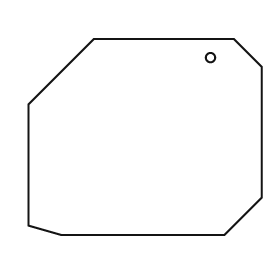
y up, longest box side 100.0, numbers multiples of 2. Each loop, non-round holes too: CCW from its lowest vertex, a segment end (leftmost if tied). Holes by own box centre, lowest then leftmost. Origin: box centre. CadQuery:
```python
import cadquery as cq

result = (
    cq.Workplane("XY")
    .moveTo(-36.0, -42.0)
    .lineTo(34.0, -42.0)
    .lineTo(50.0, -26.0)
    .lineTo(50.0, 30.0)
    .lineTo(38.0, 42.0)
    .lineTo(-22.0, 42.0)
    .lineTo(-50.0, 14.0)
    .lineTo(-50.0, -38.0)
    .close()
    .moveTo(28.0, 34.0)
    .circle(2.0)
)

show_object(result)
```